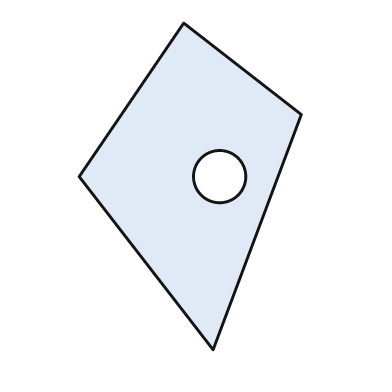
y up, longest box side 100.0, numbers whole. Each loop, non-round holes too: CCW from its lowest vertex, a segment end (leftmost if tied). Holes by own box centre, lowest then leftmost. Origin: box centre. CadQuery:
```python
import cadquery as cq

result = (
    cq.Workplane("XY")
    .moveTo(7.0, -50.0)
    .lineTo(34.0, 22.0)
    .lineTo(-2.0, 50.0)
    .lineTo(-34.0, 3.0)
    .close()
    .moveTo(9.0, 3.0)
    .circle(8.0)
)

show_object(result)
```